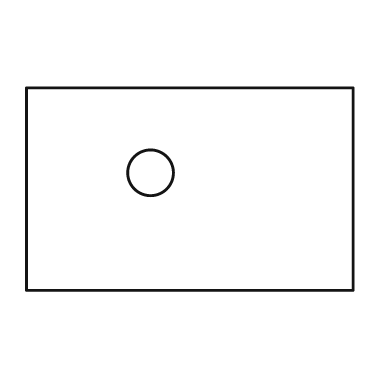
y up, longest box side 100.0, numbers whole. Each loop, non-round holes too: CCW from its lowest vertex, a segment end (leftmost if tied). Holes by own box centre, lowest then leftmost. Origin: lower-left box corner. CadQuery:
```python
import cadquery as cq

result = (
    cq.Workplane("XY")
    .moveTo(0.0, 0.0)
    .lineTo(100.0, 0.0)
    .lineTo(100.0, 62.0)
    .lineTo(0.0, 62.0)
    .close()
    .moveTo(38.0, 36.0)
    .circle(7.0)
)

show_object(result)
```